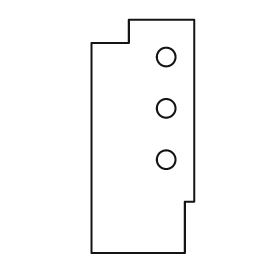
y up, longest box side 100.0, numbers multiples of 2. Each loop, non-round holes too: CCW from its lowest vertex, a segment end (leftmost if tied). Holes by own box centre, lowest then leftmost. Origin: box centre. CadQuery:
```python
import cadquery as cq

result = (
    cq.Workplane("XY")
    .moveTo(-22.0, -50.0)
    .lineTo(18.0, -50.0)
    .lineTo(18.0, -28.0)
    .lineTo(22.0, -28.0)
    .lineTo(22.0, 50.0)
    .lineTo(-6.0, 50.0)
    .lineTo(-6.0, 40.0)
    .lineTo(-22.0, 40.0)
    .close()
    .moveTo(10.0, -10.0)
    .circle(4.0)
    .moveTo(10.0, 12.0)
    .circle(4.0)
    .moveTo(10.0, 34.0)
    .circle(4.0)
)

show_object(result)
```